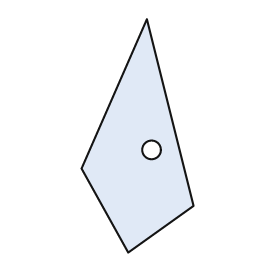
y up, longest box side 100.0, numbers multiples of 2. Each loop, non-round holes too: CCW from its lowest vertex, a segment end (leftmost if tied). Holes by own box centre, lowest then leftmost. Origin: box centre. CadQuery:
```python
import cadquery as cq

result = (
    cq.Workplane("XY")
    .moveTo(-4.0, -50.0)
    .lineTo(24.0, -30.0)
    .lineTo(4.0, 50.0)
    .lineTo(-24.0, -14.0)
    .close()
    .moveTo(6.0, -6.0)
    .circle(4.0)
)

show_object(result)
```